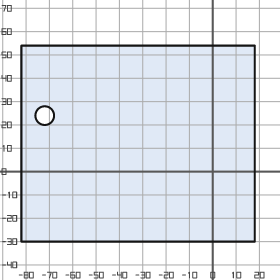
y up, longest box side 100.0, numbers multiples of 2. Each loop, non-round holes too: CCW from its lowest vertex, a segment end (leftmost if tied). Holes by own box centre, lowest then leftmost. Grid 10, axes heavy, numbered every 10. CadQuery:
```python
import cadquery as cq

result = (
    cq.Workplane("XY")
    .moveTo(-82.0, -30.0)
    .lineTo(18.0, -30.0)
    .lineTo(18.0, 54.0)
    .lineTo(-82.0, 54.0)
    .close()
    .moveTo(-72.0, 24.0)
    .circle(4.0)
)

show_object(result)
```